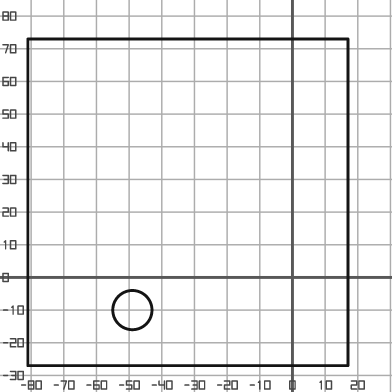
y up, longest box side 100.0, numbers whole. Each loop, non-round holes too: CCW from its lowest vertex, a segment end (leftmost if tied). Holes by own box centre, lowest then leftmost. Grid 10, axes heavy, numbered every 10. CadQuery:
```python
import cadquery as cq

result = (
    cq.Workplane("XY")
    .moveTo(-81.0, -27.0)
    .lineTo(17.0, -27.0)
    .lineTo(17.0, 73.0)
    .lineTo(-81.0, 73.0)
    .close()
    .moveTo(-49.0, -10.0)
    .circle(6.0)
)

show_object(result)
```